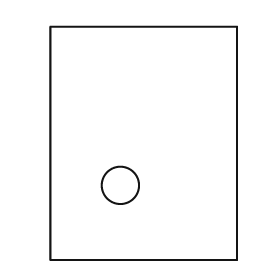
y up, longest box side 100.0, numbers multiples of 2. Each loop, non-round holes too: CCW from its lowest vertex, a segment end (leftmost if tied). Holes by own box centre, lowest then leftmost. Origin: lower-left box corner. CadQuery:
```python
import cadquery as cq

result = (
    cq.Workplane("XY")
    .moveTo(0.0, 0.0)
    .lineTo(80.0, 0.0)
    .lineTo(80.0, 100.0)
    .lineTo(0.0, 100.0)
    .close()
    .moveTo(30.0, 32.0)
    .circle(8.0)
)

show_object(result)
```